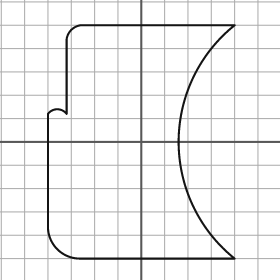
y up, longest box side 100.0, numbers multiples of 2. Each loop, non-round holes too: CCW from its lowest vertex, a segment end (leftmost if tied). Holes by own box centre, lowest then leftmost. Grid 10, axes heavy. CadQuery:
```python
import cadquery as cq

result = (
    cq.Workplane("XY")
    .moveTo(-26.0, -50.0)
    .lineTo(40.0, -50.0)
    .threePointArc((16.0, 0.0), (40.0, 50.0))
    .lineTo(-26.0, 50.0)
    .threePointArc((-30.0, 48.0), (-32.0, 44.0))
    .lineTo(-32.0, 12.0)
    .threePointArc((-36.0, 14.0), (-40.0, 12.0))
    .lineTo(-40.0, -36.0)
    .threePointArc((-36.0, -46.0), (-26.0, -50.0))
    .close()
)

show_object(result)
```